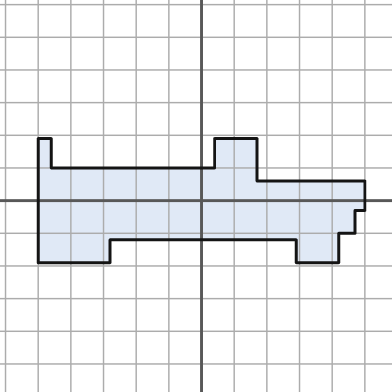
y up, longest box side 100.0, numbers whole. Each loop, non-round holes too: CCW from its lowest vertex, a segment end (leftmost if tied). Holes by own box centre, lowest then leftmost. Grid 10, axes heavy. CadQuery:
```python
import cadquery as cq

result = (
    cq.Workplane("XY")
    .moveTo(-50.0, -19.0)
    .lineTo(-28.0, -19.0)
    .lineTo(-28.0, -12.0)
    .lineTo(29.0, -12.0)
    .lineTo(29.0, -19.0)
    .lineTo(42.0, -19.0)
    .lineTo(42.0, -10.0)
    .lineTo(47.0, -10.0)
    .lineTo(47.0, -3.0)
    .lineTo(50.0, -3.0)
    .lineTo(50.0, 6.0)
    .lineTo(17.0, 6.0)
    .lineTo(17.0, 19.0)
    .lineTo(4.0, 19.0)
    .lineTo(4.0, 10.0)
    .lineTo(-46.0, 10.0)
    .lineTo(-46.0, 19.0)
    .lineTo(-50.0, 19.0)
    .close()
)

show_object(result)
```